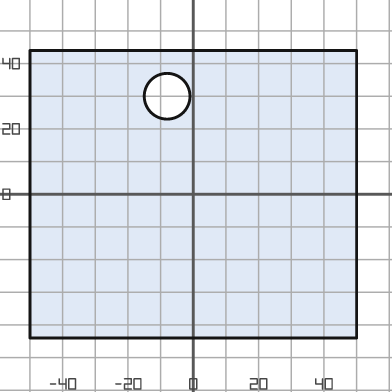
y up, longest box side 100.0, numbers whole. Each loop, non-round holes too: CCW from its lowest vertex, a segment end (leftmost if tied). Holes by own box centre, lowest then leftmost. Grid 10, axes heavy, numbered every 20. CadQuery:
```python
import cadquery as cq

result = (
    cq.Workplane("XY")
    .moveTo(-50.0, -44.0)
    .lineTo(50.0, -44.0)
    .lineTo(50.0, 44.0)
    .lineTo(-50.0, 44.0)
    .close()
    .moveTo(-8.0, 30.0)
    .circle(7.0)
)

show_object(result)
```